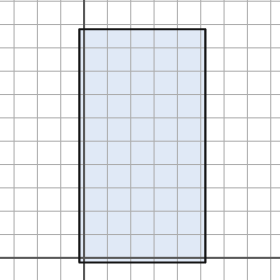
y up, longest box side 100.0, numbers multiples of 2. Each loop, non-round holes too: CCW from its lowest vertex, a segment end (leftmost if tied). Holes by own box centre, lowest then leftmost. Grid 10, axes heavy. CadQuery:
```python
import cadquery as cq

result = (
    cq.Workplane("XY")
    .moveTo(-2.0, -2.0)
    .lineTo(52.0, -2.0)
    .lineTo(52.0, 98.0)
    .lineTo(-2.0, 98.0)
    .close()
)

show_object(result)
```